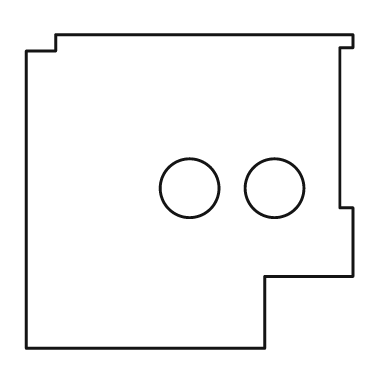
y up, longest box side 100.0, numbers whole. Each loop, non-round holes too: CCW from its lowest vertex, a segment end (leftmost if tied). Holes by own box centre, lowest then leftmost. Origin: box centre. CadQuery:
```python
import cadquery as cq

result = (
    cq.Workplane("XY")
    .moveTo(-50.0, -48.0)
    .lineTo(23.0, -48.0)
    .lineTo(23.0, -26.0)
    .lineTo(50.0, -26.0)
    .lineTo(50.0, -5.0)
    .lineTo(46.0, -5.0)
    .lineTo(46.0, 44.0)
    .lineTo(50.0, 44.0)
    .lineTo(50.0, 48.0)
    .lineTo(-41.0, 48.0)
    .lineTo(-41.0, 43.0)
    .lineTo(-50.0, 43.0)
    .close()
    .moveTo(0.0, 1.0)
    .circle(9.0)
    .moveTo(26.0, 1.0)
    .circle(9.0)
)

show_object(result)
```